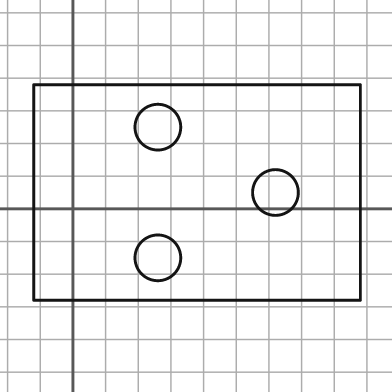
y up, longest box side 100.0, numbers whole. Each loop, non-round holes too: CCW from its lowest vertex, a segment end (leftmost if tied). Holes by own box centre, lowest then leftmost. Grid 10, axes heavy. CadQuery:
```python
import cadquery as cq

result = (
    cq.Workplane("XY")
    .moveTo(-12.0, -28.0)
    .lineTo(88.0, -28.0)
    .lineTo(88.0, 38.0)
    .lineTo(-12.0, 38.0)
    .close()
    .moveTo(26.0, -15.0)
    .circle(7.0)
    .moveTo(62.0, 5.0)
    .circle(7.0)
    .moveTo(26.0, 25.0)
    .circle(7.0)
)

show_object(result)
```